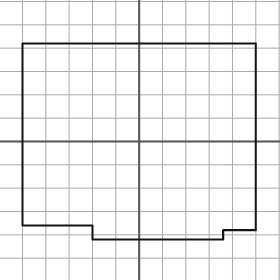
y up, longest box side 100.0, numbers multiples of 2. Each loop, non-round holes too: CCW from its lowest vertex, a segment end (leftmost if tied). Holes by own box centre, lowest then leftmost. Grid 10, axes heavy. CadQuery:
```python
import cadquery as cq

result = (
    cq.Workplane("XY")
    .moveTo(-20.0, -42.0)
    .lineTo(36.0, -42.0)
    .lineTo(36.0, -38.0)
    .lineTo(50.0, -38.0)
    .lineTo(50.0, 42.0)
    .lineTo(-50.0, 42.0)
    .lineTo(-50.0, -36.0)
    .lineTo(-20.0, -36.0)
    .close()
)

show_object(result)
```